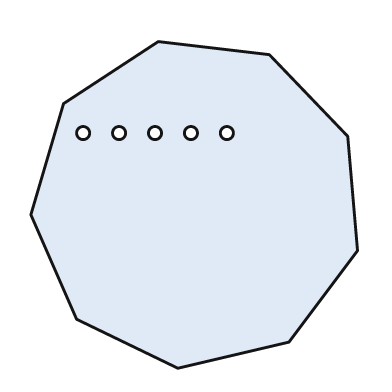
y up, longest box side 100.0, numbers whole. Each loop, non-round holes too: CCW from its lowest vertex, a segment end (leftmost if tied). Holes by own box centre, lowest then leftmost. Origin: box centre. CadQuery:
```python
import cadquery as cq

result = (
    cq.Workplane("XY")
    .moveTo(-5.0, -50.0)
    .lineTo(29.0, -42.0)
    .lineTo(50.0, -14.0)
    .lineTo(47.0, 21.0)
    .lineTo(23.0, 46.0)
    .lineTo(-11.0, 50.0)
    .lineTo(-40.0, 31.0)
    .lineTo(-50.0, -3.0)
    .lineTo(-36.0, -35.0)
    .close()
    .moveTo(-34.0, 22.0)
    .circle(2.0)
    .moveTo(-23.0, 22.0)
    .circle(2.0)
    .moveTo(-12.0, 22.0)
    .circle(2.0)
    .moveTo(-1.0, 22.0)
    .circle(2.0)
    .moveTo(10.0, 22.0)
    .circle(2.0)
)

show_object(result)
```